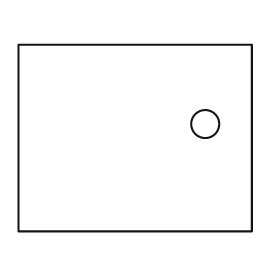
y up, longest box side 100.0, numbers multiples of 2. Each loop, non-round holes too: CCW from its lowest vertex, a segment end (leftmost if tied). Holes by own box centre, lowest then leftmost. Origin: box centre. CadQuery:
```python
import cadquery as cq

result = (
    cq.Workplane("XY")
    .moveTo(-50.0, -40.0)
    .lineTo(50.0, -40.0)
    .lineTo(50.0, 40.0)
    .lineTo(-50.0, 40.0)
    .close()
    .moveTo(30.0, 6.0)
    .circle(6.0)
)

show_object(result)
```